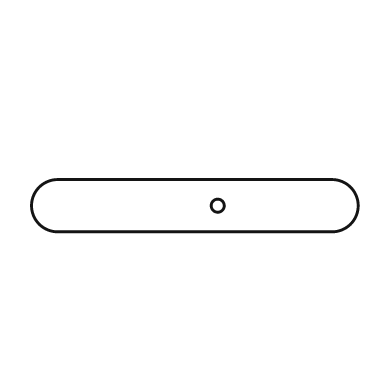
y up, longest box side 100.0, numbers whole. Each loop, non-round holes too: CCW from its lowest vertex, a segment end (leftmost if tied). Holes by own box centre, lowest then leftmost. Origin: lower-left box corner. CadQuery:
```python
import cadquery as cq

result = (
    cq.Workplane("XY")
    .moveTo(8.0, 0.0)
    .lineTo(92.0, 0.0)
    .threePointArc((100.0, 8.0), (92.0, 16.0))
    .lineTo(8.0, 16.0)
    .threePointArc((0.0, 8.0), (8.0, 0.0))
    .close()
    .moveTo(57.0, 8.0)
    .circle(2.0)
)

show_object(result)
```